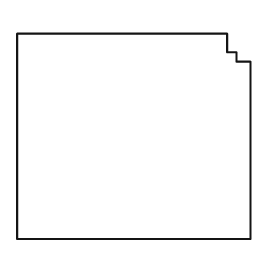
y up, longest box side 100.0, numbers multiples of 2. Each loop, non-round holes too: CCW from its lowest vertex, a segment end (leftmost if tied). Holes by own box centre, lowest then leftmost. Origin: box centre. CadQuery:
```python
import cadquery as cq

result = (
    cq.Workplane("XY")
    .moveTo(-50.0, -44.0)
    .lineTo(50.0, -44.0)
    .lineTo(50.0, 32.0)
    .lineTo(44.0, 32.0)
    .lineTo(44.0, 36.0)
    .lineTo(40.0, 36.0)
    .lineTo(40.0, 44.0)
    .lineTo(-50.0, 44.0)
    .close()
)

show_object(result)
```